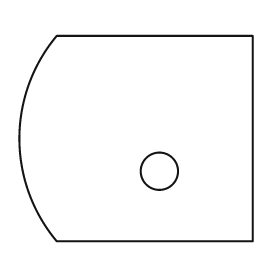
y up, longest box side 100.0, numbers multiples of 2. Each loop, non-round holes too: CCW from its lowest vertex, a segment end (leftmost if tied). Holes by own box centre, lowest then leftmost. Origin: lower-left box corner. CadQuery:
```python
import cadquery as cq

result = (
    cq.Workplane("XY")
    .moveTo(16.0, 0.0)
    .lineTo(100.0, 0.0)
    .lineTo(100.0, 88.0)
    .lineTo(16.0, 88.0)
    .threePointArc((0.0, 44.0), (16.0, 0.0))
    .close()
    .moveTo(60.0, 30.0)
    .circle(8.0)
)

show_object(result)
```